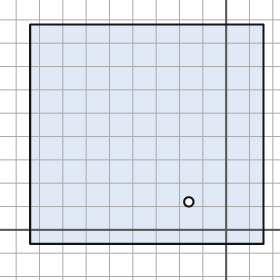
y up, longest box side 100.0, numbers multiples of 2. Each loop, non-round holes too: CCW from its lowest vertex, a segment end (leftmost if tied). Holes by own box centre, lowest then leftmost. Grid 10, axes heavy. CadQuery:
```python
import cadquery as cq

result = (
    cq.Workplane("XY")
    .moveTo(-84.0, -6.0)
    .lineTo(16.0, -6.0)
    .lineTo(16.0, 88.0)
    .lineTo(-84.0, 88.0)
    .close()
    .moveTo(-16.0, 12.0)
    .circle(2.0)
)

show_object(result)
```